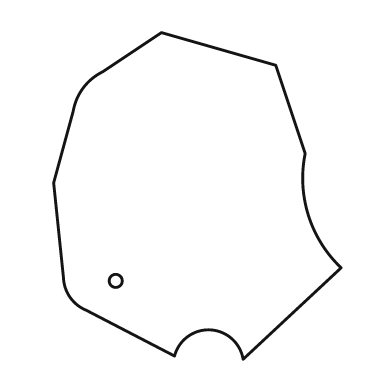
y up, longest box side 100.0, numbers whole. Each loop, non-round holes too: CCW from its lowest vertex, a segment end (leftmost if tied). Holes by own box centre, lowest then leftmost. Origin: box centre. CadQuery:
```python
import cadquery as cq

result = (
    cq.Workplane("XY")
    .moveTo(14.0, -50.0)
    .lineTo(44.0, -22.0)
    .threePointArc((34.0, -6.0), (33.0, 13.0))
    .lineTo(24.0, 40.0)
    .lineTo(-11.0, 50.0)
    .lineTo(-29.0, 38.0)
    .threePointArc((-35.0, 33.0), (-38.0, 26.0))
    .lineTo(-44.0, 4.0)
    .lineTo(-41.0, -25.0)
    .threePointArc((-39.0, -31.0), (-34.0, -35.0))
    .lineTo(-7.0, -49.0)
    .threePointArc((4.0, -41.0), (14.0, -50.0))
    .close()
    .moveTo(-25.0, -26.0)
    .circle(2.0)
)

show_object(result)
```